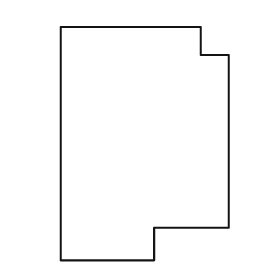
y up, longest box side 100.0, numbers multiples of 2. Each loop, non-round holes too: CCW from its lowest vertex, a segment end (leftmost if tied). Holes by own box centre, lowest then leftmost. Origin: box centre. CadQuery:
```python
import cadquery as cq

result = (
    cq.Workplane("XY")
    .moveTo(-36.0, -50.0)
    .lineTo(4.0, -50.0)
    .lineTo(4.0, -36.0)
    .lineTo(36.0, -36.0)
    .lineTo(36.0, 38.0)
    .lineTo(24.0, 38.0)
    .lineTo(24.0, 50.0)
    .lineTo(-36.0, 50.0)
    .close()
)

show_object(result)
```